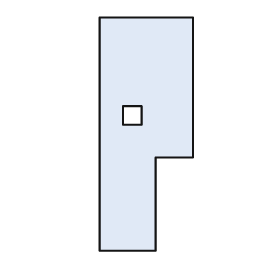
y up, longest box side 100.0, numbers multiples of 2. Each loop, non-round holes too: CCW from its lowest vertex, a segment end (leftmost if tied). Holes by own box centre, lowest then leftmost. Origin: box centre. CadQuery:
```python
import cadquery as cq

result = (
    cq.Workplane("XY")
    .moveTo(-20.0, -50.0)
    .lineTo(4.0, -50.0)
    .lineTo(4.0, -10.0)
    .lineTo(20.0, -10.0)
    .lineTo(20.0, 50.0)
    .lineTo(-20.0, 50.0)
    .close()
    .moveTo(-10.0, 4.0)
    .lineTo(-2.0, 4.0)
    .lineTo(-2.0, 12.0)
    .lineTo(-10.0, 12.0)
    .close()
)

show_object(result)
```